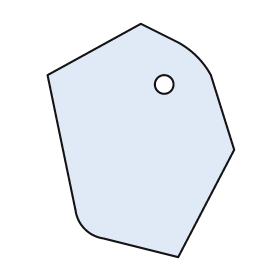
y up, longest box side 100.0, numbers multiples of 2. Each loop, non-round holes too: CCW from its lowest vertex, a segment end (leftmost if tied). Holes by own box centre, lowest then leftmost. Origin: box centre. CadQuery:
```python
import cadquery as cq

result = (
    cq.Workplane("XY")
    .moveTo(16.0, -50.0)
    .lineTo(40.0, -4.0)
    .lineTo(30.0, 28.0)
    .threePointArc((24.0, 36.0), (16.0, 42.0))
    .lineTo(0.0, 50.0)
    .lineTo(-40.0, 28.0)
    .lineTo(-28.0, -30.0)
    .threePointArc((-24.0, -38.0), (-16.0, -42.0))
    .close()
    .moveTo(10.0, 24.0)
    .circle(4.0)
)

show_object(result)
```